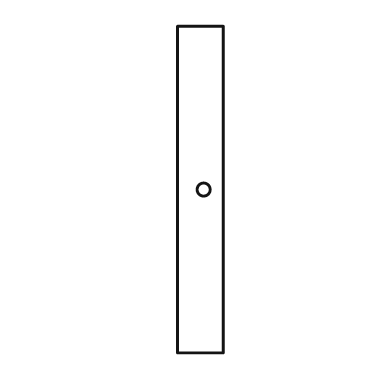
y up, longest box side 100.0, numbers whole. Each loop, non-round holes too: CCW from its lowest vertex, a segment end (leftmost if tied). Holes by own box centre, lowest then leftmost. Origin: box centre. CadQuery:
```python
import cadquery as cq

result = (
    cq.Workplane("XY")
    .moveTo(-7.0, -50.0)
    .lineTo(7.0, -50.0)
    .lineTo(7.0, 50.0)
    .lineTo(-7.0, 50.0)
    .close()
    .moveTo(1.0, 0.0)
    .circle(2.0)
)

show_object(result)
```